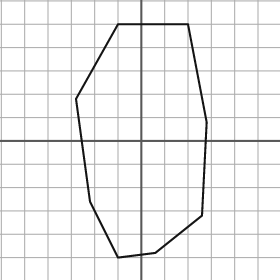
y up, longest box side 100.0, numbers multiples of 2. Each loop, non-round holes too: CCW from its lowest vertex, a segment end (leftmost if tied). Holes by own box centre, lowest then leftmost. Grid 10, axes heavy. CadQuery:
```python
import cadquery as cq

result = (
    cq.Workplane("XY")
    .moveTo(-10.0, -50.0)
    .lineTo(6.0, -48.0)
    .lineTo(26.0, -32.0)
    .lineTo(28.0, 8.0)
    .lineTo(20.0, 50.0)
    .lineTo(-10.0, 50.0)
    .lineTo(-28.0, 18.0)
    .lineTo(-22.0, -26.0)
    .close()
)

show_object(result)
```